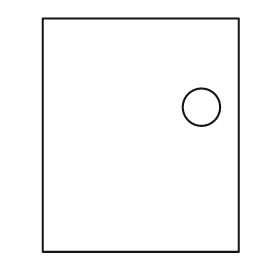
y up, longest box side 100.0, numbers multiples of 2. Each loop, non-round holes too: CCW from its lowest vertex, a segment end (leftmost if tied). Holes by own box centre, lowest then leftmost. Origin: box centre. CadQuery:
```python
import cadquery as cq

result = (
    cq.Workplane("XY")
    .moveTo(-42.0, -50.0)
    .lineTo(42.0, -50.0)
    .lineTo(42.0, 50.0)
    .lineTo(-42.0, 50.0)
    .close()
    .moveTo(26.0, 12.0)
    .circle(8.0)
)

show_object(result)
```